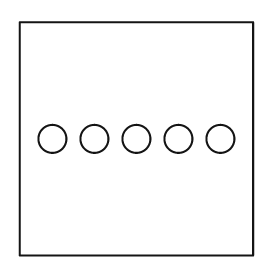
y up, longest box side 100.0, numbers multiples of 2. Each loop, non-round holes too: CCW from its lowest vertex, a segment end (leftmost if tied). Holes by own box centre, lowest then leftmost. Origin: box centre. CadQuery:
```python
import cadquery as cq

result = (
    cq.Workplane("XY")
    .moveTo(-50.0, -50.0)
    .lineTo(50.0, -50.0)
    .lineTo(50.0, 50.0)
    .lineTo(-50.0, 50.0)
    .close()
    .moveTo(-36.0, 0.0)
    .circle(6.0)
    .moveTo(-18.0, 0.0)
    .circle(6.0)
    .moveTo(0.0, 0.0)
    .circle(6.0)
    .moveTo(18.0, 0.0)
    .circle(6.0)
    .moveTo(36.0, 0.0)
    .circle(6.0)
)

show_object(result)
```